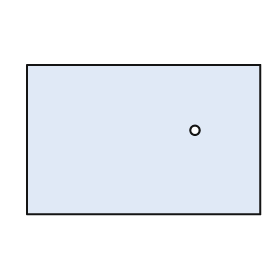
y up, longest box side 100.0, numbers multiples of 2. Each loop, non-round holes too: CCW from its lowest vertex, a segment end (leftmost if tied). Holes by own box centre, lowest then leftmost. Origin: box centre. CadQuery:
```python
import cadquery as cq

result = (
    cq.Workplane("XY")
    .moveTo(-50.0, -32.0)
    .lineTo(50.0, -32.0)
    .lineTo(50.0, 32.0)
    .lineTo(-50.0, 32.0)
    .close()
    .moveTo(22.0, 4.0)
    .circle(2.0)
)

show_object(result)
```